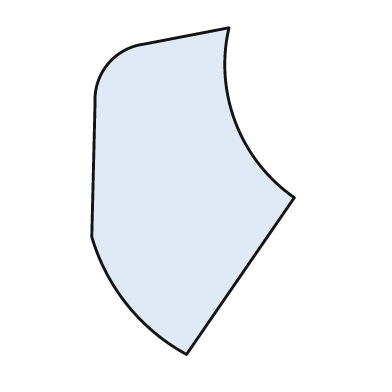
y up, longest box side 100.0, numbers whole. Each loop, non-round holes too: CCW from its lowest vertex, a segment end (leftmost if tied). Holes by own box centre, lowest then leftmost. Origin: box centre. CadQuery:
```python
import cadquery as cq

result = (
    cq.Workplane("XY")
    .moveTo(-2.0, -50.0)
    .lineTo(31.0, -2.0)
    .threePointArc((13.0, 21.0), (11.0, 50.0))
    .lineTo(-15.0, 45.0)
    .threePointArc((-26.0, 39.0), (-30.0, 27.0))
    .lineTo(-31.0, -14.0)
    .threePointArc((-20.0, -35.0), (-2.0, -50.0))
    .close()
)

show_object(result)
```